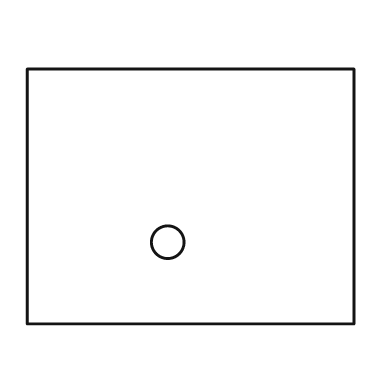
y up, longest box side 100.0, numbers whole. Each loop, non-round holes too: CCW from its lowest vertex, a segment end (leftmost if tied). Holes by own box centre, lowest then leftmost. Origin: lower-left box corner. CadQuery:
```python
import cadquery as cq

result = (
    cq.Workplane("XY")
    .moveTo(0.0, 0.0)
    .lineTo(100.0, 0.0)
    .lineTo(100.0, 78.0)
    .lineTo(0.0, 78.0)
    .close()
    .moveTo(43.0, 25.0)
    .circle(5.0)
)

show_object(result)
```